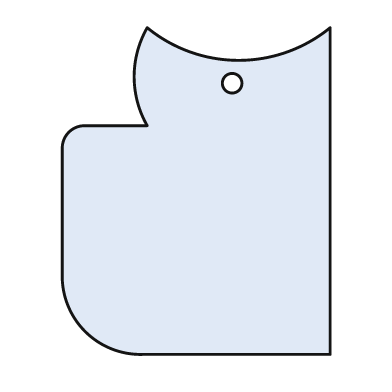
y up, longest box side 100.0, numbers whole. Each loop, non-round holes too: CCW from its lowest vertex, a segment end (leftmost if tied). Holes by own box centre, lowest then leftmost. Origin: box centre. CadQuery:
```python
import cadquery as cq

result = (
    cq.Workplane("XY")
    .moveTo(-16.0, -50.0)
    .lineTo(41.0, -50.0)
    .lineTo(41.0, 50.0)
    .threePointArc((13.0, 40.0), (-15.0, 50.0))
    .threePointArc((-19.0, 35.0), (-15.0, 20.0))
    .lineTo(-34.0, 20.0)
    .threePointArc((-39.0, 18.0), (-41.0, 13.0))
    .lineTo(-41.0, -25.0)
    .threePointArc((-34.0, -43.0), (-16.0, -50.0))
    .close()
    .moveTo(11.0, 33.0)
    .circle(3.0)
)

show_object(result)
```